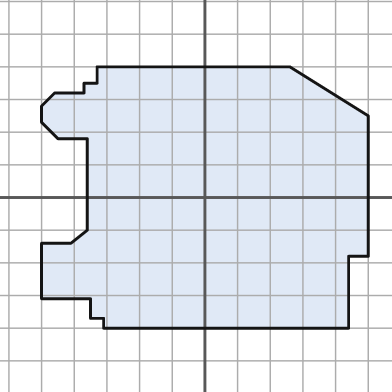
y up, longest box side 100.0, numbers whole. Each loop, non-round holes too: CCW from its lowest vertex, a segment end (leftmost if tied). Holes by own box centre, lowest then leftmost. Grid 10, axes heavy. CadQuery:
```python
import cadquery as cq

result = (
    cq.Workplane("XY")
    .moveTo(-31.0, -40.0)
    .lineTo(44.0, -40.0)
    .lineTo(44.0, -18.0)
    .lineTo(50.0, -18.0)
    .lineTo(50.0, 25.0)
    .lineTo(26.0, 40.0)
    .lineTo(-33.0, 40.0)
    .lineTo(-33.0, 35.0)
    .lineTo(-37.0, 35.0)
    .lineTo(-37.0, 32.0)
    .lineTo(-46.0, 32.0)
    .lineTo(-50.0, 28.0)
    .lineTo(-50.0, 23.0)
    .lineTo(-45.0, 18.0)
    .lineTo(-36.0, 18.0)
    .lineTo(-36.0, -10.0)
    .lineTo(-41.0, -14.0)
    .lineTo(-50.0, -14.0)
    .lineTo(-50.0, -31.0)
    .lineTo(-35.0, -31.0)
    .lineTo(-35.0, -37.0)
    .lineTo(-31.0, -37.0)
    .close()
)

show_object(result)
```